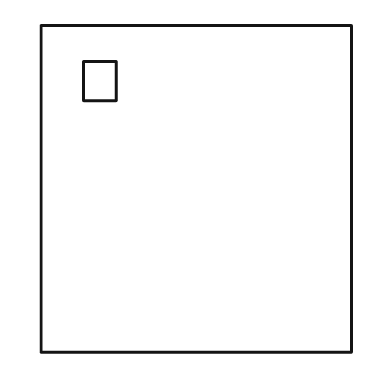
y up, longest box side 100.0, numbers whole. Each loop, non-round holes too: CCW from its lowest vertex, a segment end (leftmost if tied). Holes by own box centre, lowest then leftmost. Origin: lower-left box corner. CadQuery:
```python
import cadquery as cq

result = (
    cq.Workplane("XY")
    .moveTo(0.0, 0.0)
    .lineTo(95.0, 0.0)
    .lineTo(95.0, 100.0)
    .lineTo(0.0, 100.0)
    .close()
    .moveTo(13.0, 77.0)
    .lineTo(23.0, 77.0)
    .lineTo(23.0, 89.0)
    .lineTo(13.0, 89.0)
    .close()
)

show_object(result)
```